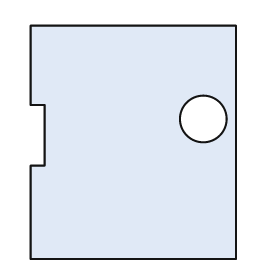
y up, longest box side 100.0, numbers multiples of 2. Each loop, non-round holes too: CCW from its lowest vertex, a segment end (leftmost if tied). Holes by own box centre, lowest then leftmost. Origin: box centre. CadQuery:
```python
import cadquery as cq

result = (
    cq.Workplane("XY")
    .moveTo(-44.0, -50.0)
    .lineTo(44.0, -50.0)
    .lineTo(44.0, 50.0)
    .lineTo(-44.0, 50.0)
    .lineTo(-44.0, 16.0)
    .lineTo(-38.0, 16.0)
    .lineTo(-38.0, -10.0)
    .lineTo(-44.0, -10.0)
    .close()
    .moveTo(30.0, 10.0)
    .circle(10.0)
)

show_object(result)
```